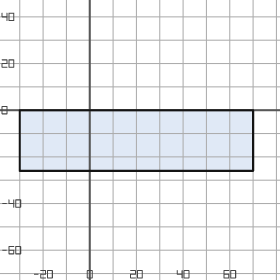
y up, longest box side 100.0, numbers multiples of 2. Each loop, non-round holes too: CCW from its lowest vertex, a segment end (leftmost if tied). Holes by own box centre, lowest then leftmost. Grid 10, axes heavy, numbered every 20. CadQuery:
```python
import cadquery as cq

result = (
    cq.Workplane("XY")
    .moveTo(-30.0, -26.0)
    .lineTo(70.0, -26.0)
    .lineTo(70.0, 0.0)
    .lineTo(-30.0, 0.0)
    .close()
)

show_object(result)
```